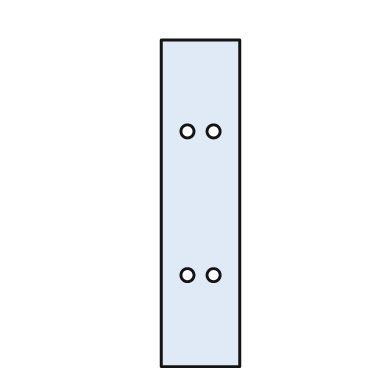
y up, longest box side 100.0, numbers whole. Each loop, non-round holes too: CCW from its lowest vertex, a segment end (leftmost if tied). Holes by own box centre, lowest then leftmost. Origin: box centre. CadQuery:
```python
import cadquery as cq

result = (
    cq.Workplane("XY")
    .moveTo(-12.0, -50.0)
    .lineTo(12.0, -50.0)
    .lineTo(12.0, 50.0)
    .lineTo(-12.0, 50.0)
    .close()
    .moveTo(-4.0, -22.0)
    .circle(2.0)
    .moveTo(4.0, -22.0)
    .circle(2.0)
    .moveTo(-4.0, 22.0)
    .circle(2.0)
    .moveTo(4.0, 22.0)
    .circle(2.0)
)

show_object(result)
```